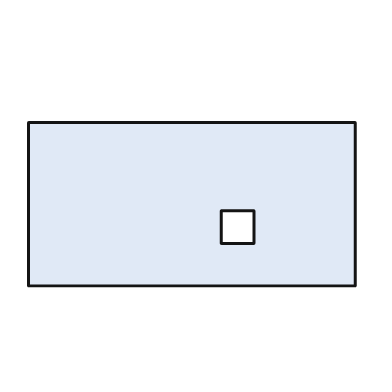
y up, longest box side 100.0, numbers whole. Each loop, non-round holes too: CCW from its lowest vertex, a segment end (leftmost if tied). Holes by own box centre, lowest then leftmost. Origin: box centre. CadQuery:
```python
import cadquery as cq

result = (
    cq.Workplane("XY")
    .moveTo(-50.0, -25.0)
    .lineTo(50.0, -25.0)
    .lineTo(50.0, 25.0)
    .lineTo(-50.0, 25.0)
    .close()
    .moveTo(9.0, -12.0)
    .lineTo(19.0, -12.0)
    .lineTo(19.0, -2.0)
    .lineTo(9.0, -2.0)
    .close()
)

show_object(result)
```